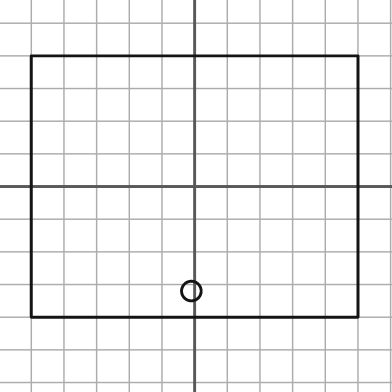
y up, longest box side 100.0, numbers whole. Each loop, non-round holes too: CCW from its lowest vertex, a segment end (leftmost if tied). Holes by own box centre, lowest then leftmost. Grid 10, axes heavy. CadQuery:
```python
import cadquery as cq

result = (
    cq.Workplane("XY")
    .moveTo(-50.0, -40.0)
    .lineTo(50.0, -40.0)
    .lineTo(50.0, 40.0)
    .lineTo(-50.0, 40.0)
    .close()
    .moveTo(-1.0, -32.0)
    .circle(3.0)
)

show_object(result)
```